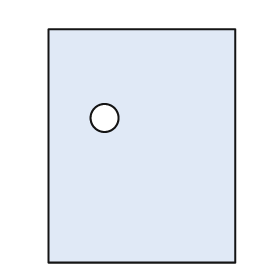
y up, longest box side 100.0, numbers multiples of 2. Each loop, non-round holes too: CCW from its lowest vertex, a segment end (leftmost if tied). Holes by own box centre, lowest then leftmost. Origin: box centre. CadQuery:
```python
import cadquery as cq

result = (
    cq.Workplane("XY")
    .moveTo(-40.0, -50.0)
    .lineTo(40.0, -50.0)
    .lineTo(40.0, 50.0)
    .lineTo(-40.0, 50.0)
    .close()
    .moveTo(-16.0, 12.0)
    .circle(6.0)
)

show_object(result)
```